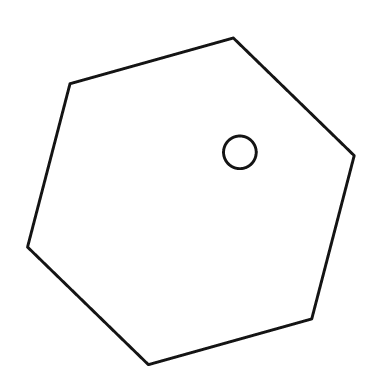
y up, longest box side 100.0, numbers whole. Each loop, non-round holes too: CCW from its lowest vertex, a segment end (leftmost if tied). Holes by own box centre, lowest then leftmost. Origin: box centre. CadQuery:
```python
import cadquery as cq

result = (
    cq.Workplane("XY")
    .moveTo(-13.0, -50.0)
    .lineTo(37.0, -36.0)
    .lineTo(50.0, 14.0)
    .lineTo(13.0, 50.0)
    .lineTo(-37.0, 36.0)
    .lineTo(-50.0, -14.0)
    .close()
    .moveTo(15.0, 15.0)
    .circle(5.0)
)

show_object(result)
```